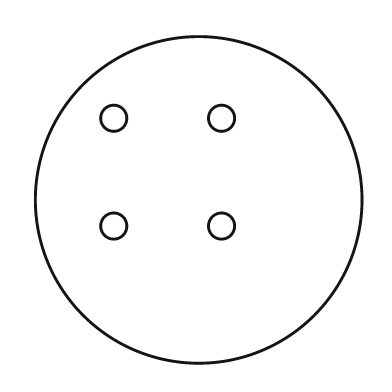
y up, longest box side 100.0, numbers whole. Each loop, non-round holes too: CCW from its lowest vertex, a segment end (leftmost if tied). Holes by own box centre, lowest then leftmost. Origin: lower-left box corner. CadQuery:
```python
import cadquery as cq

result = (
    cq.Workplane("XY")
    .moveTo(50.0, 50.0)
    .circle(50.0)
    .moveTo(24.0, 42.0)
    .circle(4.0)
    .moveTo(57.0, 42.0)
    .circle(4.0)
    .moveTo(24.0, 75.0)
    .circle(4.0)
    .moveTo(57.0, 75.0)
    .circle(4.0)
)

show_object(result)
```